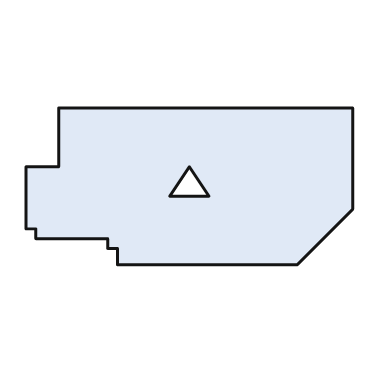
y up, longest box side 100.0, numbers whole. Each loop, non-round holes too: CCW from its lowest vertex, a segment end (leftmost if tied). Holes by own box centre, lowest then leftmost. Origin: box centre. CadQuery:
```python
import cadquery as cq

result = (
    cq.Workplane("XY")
    .moveTo(-22.0, -24.0)
    .lineTo(33.0, -24.0)
    .lineTo(50.0, -7.0)
    .lineTo(50.0, 24.0)
    .lineTo(-40.0, 24.0)
    .lineTo(-40.0, 6.0)
    .lineTo(-50.0, 6.0)
    .lineTo(-50.0, -13.0)
    .lineTo(-47.0, -13.0)
    .lineTo(-47.0, -16.0)
    .lineTo(-25.0, -16.0)
    .lineTo(-25.0, -19.0)
    .lineTo(-22.0, -19.0)
    .close()
    .moveTo(-6.0, -3.0)
    .lineTo(6.0, -3.0)
    .lineTo(0.0, 6.0)
    .close()
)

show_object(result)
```